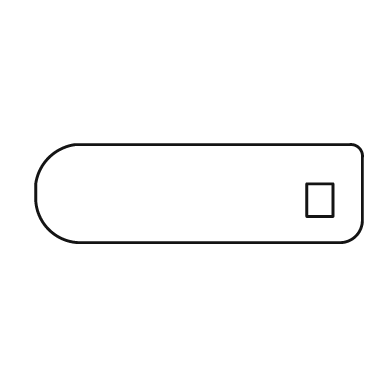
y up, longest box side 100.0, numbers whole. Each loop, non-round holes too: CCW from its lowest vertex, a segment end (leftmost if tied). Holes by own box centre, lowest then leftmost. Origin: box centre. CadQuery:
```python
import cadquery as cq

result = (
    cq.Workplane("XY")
    .moveTo(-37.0, -15.0)
    .lineTo(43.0, -15.0)
    .threePointArc((48.0, -13.0), (50.0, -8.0))
    .lineTo(50.0, 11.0)
    .threePointArc((49.0, 14.0), (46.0, 15.0))
    .lineTo(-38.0, 15.0)
    .threePointArc((-46.0, 11.0), (-50.0, 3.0))
    .lineTo(-50.0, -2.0)
    .threePointArc((-46.0, -11.0), (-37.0, -15.0))
    .close()
    .moveTo(33.0, -7.0)
    .lineTo(41.0, -7.0)
    .lineTo(41.0, 3.0)
    .lineTo(33.0, 3.0)
    .close()
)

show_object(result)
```